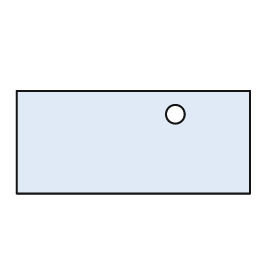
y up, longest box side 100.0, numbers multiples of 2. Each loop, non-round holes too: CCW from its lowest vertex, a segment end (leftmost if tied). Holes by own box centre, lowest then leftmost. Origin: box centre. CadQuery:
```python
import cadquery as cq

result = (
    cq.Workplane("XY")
    .moveTo(-50.0, -22.0)
    .lineTo(50.0, -22.0)
    .lineTo(50.0, 22.0)
    .lineTo(-50.0, 22.0)
    .close()
    .moveTo(18.0, 12.0)
    .circle(4.0)
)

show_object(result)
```